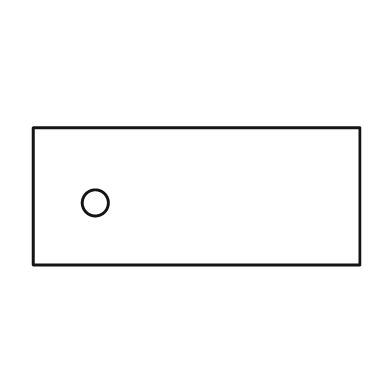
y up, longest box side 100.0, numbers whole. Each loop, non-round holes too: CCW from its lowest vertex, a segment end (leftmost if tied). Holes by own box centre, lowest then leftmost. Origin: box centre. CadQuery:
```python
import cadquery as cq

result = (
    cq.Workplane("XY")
    .moveTo(-50.0, -21.0)
    .lineTo(50.0, -21.0)
    .lineTo(50.0, 21.0)
    .lineTo(-50.0, 21.0)
    .close()
    .moveTo(-31.0, -2.0)
    .circle(4.0)
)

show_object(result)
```